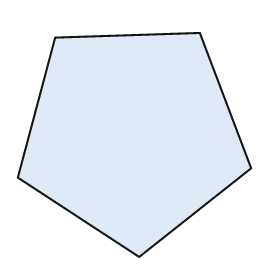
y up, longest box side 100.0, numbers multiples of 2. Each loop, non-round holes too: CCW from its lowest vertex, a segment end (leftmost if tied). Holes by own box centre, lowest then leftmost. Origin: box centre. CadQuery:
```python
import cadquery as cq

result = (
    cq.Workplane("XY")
    .moveTo(2.0, -48.0)
    .lineTo(50.0, -10.0)
    .lineTo(28.0, 48.0)
    .lineTo(-34.0, 46.0)
    .lineTo(-50.0, -14.0)
    .close()
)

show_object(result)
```